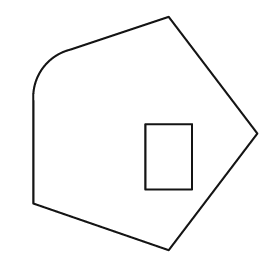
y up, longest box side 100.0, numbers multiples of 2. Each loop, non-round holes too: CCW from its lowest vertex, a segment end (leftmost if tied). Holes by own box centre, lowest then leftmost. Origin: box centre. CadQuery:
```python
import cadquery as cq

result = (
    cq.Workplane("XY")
    .moveTo(10.0, -50.0)
    .lineTo(48.0, 0.0)
    .lineTo(10.0, 50.0)
    .lineTo(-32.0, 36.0)
    .threePointArc((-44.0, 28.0), (-48.0, 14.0))
    .lineTo(-48.0, -30.0)
    .close()
    .moveTo(0.0, -24.0)
    .lineTo(20.0, -24.0)
    .lineTo(20.0, 4.0)
    .lineTo(0.0, 4.0)
    .close()
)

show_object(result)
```